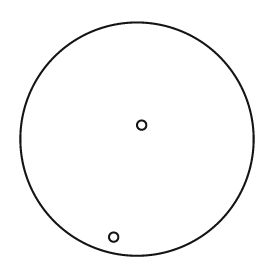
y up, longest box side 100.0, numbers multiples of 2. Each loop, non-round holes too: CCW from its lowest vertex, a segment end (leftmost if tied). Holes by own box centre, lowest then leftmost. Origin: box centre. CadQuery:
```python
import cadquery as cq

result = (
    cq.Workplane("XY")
    .moveTo(0.0, 0.0)
    .circle(50.0)
    .moveTo(-10.0, -42.0)
    .circle(2.0)
    .moveTo(2.0, 6.0)
    .circle(2.0)
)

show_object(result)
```